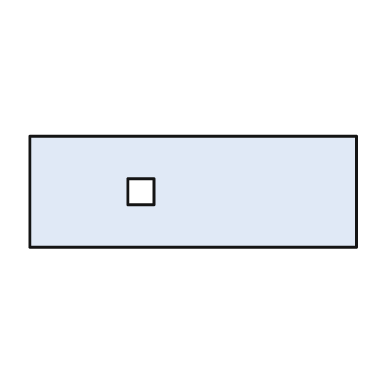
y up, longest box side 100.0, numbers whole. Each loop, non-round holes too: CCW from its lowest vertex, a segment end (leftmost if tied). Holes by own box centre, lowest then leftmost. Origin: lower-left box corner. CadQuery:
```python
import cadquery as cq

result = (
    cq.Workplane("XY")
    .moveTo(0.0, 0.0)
    .lineTo(100.0, 0.0)
    .lineTo(100.0, 34.0)
    .lineTo(0.0, 34.0)
    .close()
    .moveTo(30.0, 13.0)
    .lineTo(38.0, 13.0)
    .lineTo(38.0, 21.0)
    .lineTo(30.0, 21.0)
    .close()
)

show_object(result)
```